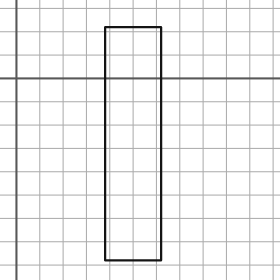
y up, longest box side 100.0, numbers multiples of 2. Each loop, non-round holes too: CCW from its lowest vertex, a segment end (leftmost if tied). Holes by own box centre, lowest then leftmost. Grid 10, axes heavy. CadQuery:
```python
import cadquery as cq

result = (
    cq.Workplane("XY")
    .moveTo(38.0, -78.0)
    .lineTo(62.0, -78.0)
    .lineTo(62.0, 22.0)
    .lineTo(38.0, 22.0)
    .close()
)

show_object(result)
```